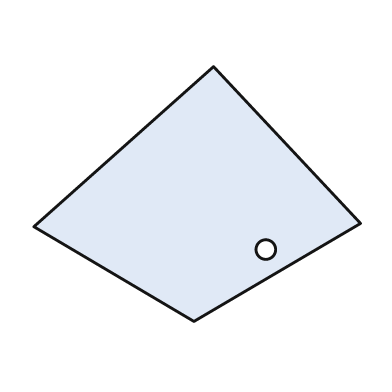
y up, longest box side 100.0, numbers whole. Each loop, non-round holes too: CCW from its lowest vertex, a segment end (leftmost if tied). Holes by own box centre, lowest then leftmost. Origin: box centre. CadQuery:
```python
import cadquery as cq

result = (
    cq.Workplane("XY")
    .moveTo(-1.0, -39.0)
    .lineTo(50.0, -9.0)
    .lineTo(5.0, 39.0)
    .lineTo(-50.0, -10.0)
    .close()
    .moveTo(21.0, -17.0)
    .circle(3.0)
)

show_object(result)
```